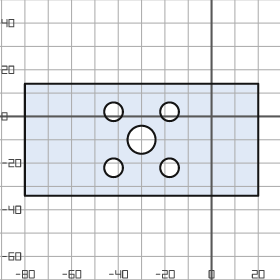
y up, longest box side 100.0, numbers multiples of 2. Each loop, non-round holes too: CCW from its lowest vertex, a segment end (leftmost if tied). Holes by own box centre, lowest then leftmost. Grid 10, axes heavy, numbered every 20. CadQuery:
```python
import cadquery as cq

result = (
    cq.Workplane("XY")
    .moveTo(-80.0, -34.0)
    .lineTo(20.0, -34.0)
    .lineTo(20.0, 14.0)
    .lineTo(-80.0, 14.0)
    .close()
    .moveTo(-42.0, -22.0)
    .circle(4.0)
    .moveTo(-18.0, -22.0)
    .circle(4.0)
    .moveTo(-30.0, -10.0)
    .circle(6.0)
    .moveTo(-42.0, 2.0)
    .circle(4.0)
    .moveTo(-18.0, 2.0)
    .circle(4.0)
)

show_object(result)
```